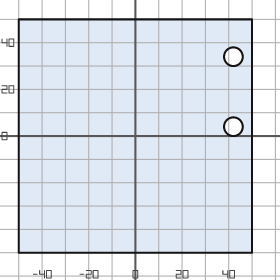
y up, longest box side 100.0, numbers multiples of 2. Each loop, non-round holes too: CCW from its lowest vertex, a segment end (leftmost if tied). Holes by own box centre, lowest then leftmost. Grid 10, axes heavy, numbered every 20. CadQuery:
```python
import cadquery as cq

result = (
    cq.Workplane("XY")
    .moveTo(-50.0, -50.0)
    .lineTo(50.0, -50.0)
    .lineTo(50.0, 50.0)
    .lineTo(-50.0, 50.0)
    .close()
    .moveTo(42.0, 4.0)
    .circle(4.0)
    .moveTo(42.0, 34.0)
    .circle(4.0)
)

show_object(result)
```